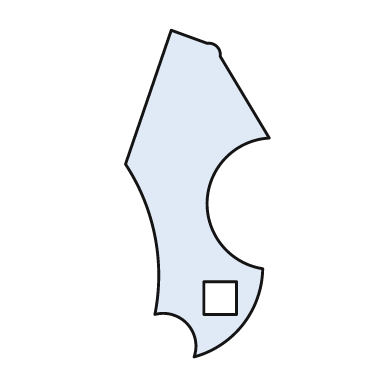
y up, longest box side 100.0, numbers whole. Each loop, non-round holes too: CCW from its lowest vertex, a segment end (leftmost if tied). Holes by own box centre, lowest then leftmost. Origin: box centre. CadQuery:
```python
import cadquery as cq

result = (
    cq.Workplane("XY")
    .moveTo(-1.0, -50.0)
    .threePointArc((14.0, -40.0), (20.0, -23.0))
    .threePointArc((3.0, -2.0), (22.0, 17.0))
    .lineTo(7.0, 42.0)
    .threePointArc((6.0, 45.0), (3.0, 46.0))
    .lineTo(-8.0, 50.0)
    .lineTo(-22.0, 9.0)
    .threePointArc((-13.0, -13.0), (-13.0, -37.0))
    .threePointArc((-3.0, -40.0), (-1.0, -50.0))
    .close()
    .moveTo(2.0, -37.0)
    .lineTo(12.0, -37.0)
    .lineTo(12.0, -27.0)
    .lineTo(2.0, -27.0)
    .close()
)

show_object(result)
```